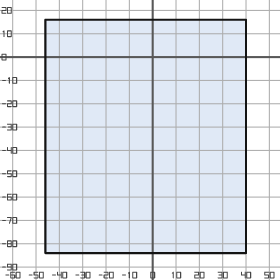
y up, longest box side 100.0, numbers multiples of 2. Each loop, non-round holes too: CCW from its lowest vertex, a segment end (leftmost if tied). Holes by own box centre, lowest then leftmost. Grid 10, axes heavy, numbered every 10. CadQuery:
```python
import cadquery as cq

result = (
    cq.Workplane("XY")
    .moveTo(-46.0, -84.0)
    .lineTo(40.0, -84.0)
    .lineTo(40.0, 16.0)
    .lineTo(-46.0, 16.0)
    .close()
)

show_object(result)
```